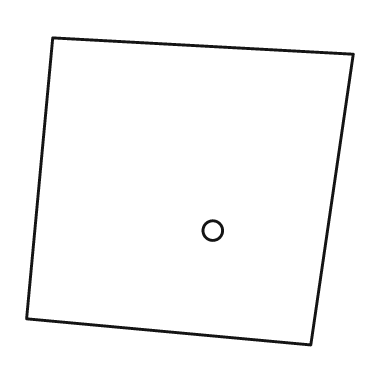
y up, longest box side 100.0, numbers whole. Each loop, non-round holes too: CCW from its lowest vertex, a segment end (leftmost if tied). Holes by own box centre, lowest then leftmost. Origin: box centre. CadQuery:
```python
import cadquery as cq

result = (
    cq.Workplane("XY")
    .moveTo(37.0, -47.0)
    .lineTo(50.0, 42.0)
    .lineTo(-42.0, 47.0)
    .lineTo(-50.0, -39.0)
    .close()
    .moveTo(7.0, -12.0)
    .circle(3.0)
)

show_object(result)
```